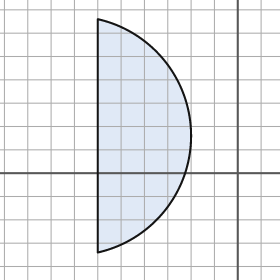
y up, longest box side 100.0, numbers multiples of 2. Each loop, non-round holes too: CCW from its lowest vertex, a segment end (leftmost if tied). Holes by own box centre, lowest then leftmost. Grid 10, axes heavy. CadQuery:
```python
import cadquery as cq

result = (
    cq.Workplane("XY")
    .moveTo(-60.0, -34.0)
    .threePointArc((-20.0, 16.0), (-60.0, 66.0))
    .close()
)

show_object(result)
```